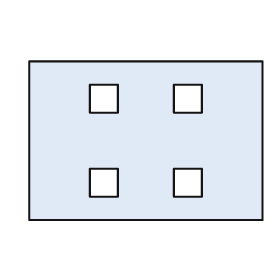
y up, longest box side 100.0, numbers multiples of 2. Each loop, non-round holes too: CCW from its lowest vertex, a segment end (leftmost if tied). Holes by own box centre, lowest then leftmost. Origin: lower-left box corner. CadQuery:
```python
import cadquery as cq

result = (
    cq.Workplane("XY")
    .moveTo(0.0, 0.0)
    .lineTo(100.0, 0.0)
    .lineTo(100.0, 68.0)
    .lineTo(0.0, 68.0)
    .close()
    .moveTo(26.0, 10.0)
    .lineTo(38.0, 10.0)
    .lineTo(38.0, 22.0)
    .lineTo(26.0, 22.0)
    .close()
    .moveTo(62.0, 10.0)
    .lineTo(74.0, 10.0)
    .lineTo(74.0, 22.0)
    .lineTo(62.0, 22.0)
    .close()
    .moveTo(26.0, 46.0)
    .lineTo(38.0, 46.0)
    .lineTo(38.0, 58.0)
    .lineTo(26.0, 58.0)
    .close()
    .moveTo(62.0, 46.0)
    .lineTo(74.0, 46.0)
    .lineTo(74.0, 58.0)
    .lineTo(62.0, 58.0)
    .close()
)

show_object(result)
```